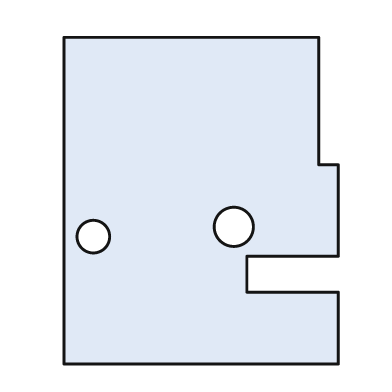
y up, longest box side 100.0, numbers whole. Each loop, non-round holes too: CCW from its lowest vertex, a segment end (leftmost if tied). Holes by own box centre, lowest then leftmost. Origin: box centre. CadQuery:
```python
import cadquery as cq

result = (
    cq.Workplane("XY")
    .moveTo(-42.0, -50.0)
    .lineTo(42.0, -50.0)
    .lineTo(42.0, -28.0)
    .lineTo(14.0, -28.0)
    .lineTo(14.0, -17.0)
    .lineTo(42.0, -17.0)
    .lineTo(42.0, 11.0)
    .lineTo(36.0, 11.0)
    .lineTo(36.0, 50.0)
    .lineTo(-42.0, 50.0)
    .close()
    .moveTo(-33.0, -11.0)
    .circle(5.0)
    .moveTo(10.0, -8.0)
    .circle(6.0)
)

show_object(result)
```